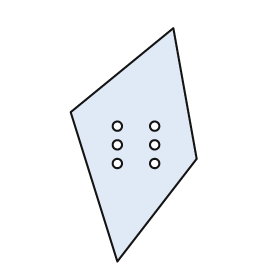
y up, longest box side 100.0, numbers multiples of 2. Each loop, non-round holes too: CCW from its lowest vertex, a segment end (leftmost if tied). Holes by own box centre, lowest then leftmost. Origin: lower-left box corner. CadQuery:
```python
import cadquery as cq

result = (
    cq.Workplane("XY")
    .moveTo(20.0, 0.0)
    .lineTo(54.0, 44.0)
    .lineTo(44.0, 100.0)
    .lineTo(0.0, 64.0)
    .close()
    .moveTo(20.0, 42.0)
    .circle(2.0)
    .moveTo(36.0, 42.0)
    .circle(2.0)
    .moveTo(20.0, 50.0)
    .circle(2.0)
    .moveTo(36.0, 50.0)
    .circle(2.0)
    .moveTo(20.0, 58.0)
    .circle(2.0)
    .moveTo(36.0, 58.0)
    .circle(2.0)
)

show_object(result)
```